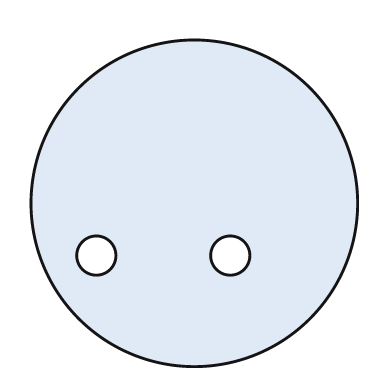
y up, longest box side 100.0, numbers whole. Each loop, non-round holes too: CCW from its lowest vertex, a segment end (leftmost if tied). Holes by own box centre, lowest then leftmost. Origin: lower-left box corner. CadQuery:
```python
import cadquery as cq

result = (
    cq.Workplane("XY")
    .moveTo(50.0, 50.0)
    .circle(50.0)
    .moveTo(20.0, 34.0)
    .circle(6.0)
    .moveTo(61.0, 34.0)
    .circle(6.0)
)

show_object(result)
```